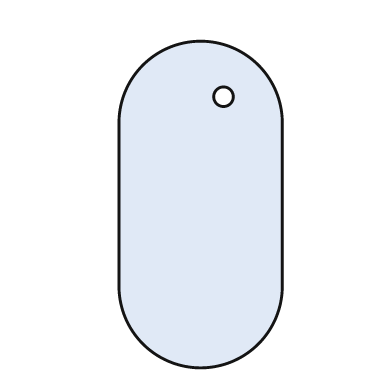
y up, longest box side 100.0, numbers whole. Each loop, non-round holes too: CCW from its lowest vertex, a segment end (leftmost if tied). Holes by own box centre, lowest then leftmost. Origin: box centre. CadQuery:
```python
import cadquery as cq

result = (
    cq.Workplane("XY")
    .moveTo(-25.0, -25.0)
    .threePointArc((0.0, -50.0), (25.0, -25.0))
    .lineTo(25.0, 25.0)
    .threePointArc((0.0, 50.0), (-25.0, 25.0))
    .close()
    .moveTo(7.0, 33.0)
    .circle(3.0)
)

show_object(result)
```